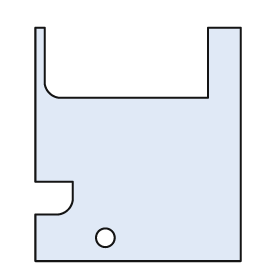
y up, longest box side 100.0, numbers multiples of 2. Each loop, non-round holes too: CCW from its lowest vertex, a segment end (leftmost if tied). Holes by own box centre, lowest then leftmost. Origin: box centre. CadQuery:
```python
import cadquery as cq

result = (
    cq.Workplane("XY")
    .moveTo(-44.0, -50.0)
    .lineTo(44.0, -50.0)
    .lineTo(44.0, 50.0)
    .lineTo(30.0, 50.0)
    .lineTo(30.0, 20.0)
    .lineTo(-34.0, 20.0)
    .threePointArc((-38.0, 22.0), (-40.0, 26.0))
    .lineTo(-40.0, 50.0)
    .lineTo(-44.0, 50.0)
    .lineTo(-44.0, -16.0)
    .lineTo(-28.0, -16.0)
    .lineTo(-28.0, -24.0)
    .threePointArc((-30.0, -28.0), (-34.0, -30.0))
    .lineTo(-44.0, -30.0)
    .close()
    .moveTo(-14.0, -40.0)
    .circle(4.0)
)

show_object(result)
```